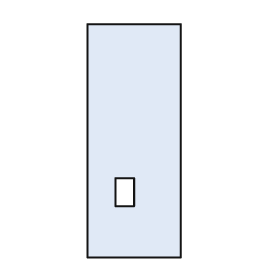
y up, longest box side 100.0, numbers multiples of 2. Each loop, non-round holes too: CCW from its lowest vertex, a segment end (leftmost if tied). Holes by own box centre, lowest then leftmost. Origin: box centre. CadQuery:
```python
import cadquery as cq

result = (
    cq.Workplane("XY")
    .moveTo(-20.0, -50.0)
    .lineTo(20.0, -50.0)
    .lineTo(20.0, 50.0)
    .lineTo(-20.0, 50.0)
    .close()
    .moveTo(-8.0, -28.0)
    .lineTo(0.0, -28.0)
    .lineTo(0.0, -16.0)
    .lineTo(-8.0, -16.0)
    .close()
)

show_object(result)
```